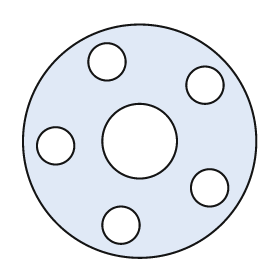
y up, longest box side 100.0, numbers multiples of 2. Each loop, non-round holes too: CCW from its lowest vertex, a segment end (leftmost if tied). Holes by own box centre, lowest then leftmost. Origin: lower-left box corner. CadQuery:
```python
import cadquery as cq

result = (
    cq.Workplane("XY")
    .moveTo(50.0, 50.0)
    .circle(50.0)
    .moveTo(42.0, 14.0)
    .circle(8.0)
    .moveTo(80.0, 30.0)
    .circle(8.0)
    .moveTo(14.0, 48.0)
    .circle(8.0)
    .moveTo(50.0, 50.0)
    .circle(16.0)
    .moveTo(78.0, 74.0)
    .circle(8.0)
    .moveTo(36.0, 84.0)
    .circle(8.0)
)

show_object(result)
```